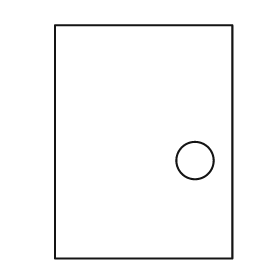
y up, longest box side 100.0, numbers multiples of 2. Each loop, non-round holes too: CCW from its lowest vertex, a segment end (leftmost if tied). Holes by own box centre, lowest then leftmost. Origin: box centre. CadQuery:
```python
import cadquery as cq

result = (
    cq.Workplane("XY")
    .moveTo(-38.0, -50.0)
    .lineTo(38.0, -50.0)
    .lineTo(38.0, 50.0)
    .lineTo(-38.0, 50.0)
    .close()
    .moveTo(22.0, -8.0)
    .circle(8.0)
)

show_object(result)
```